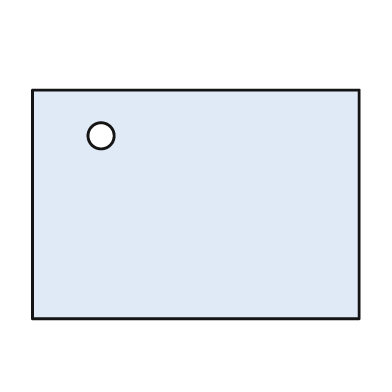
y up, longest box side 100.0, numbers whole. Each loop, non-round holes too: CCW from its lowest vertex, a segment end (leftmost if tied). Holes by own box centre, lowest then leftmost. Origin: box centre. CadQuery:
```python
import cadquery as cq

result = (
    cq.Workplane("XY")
    .moveTo(-50.0, -35.0)
    .lineTo(50.0, -35.0)
    .lineTo(50.0, 35.0)
    .lineTo(-50.0, 35.0)
    .close()
    .moveTo(-29.0, 21.0)
    .circle(4.0)
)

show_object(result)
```